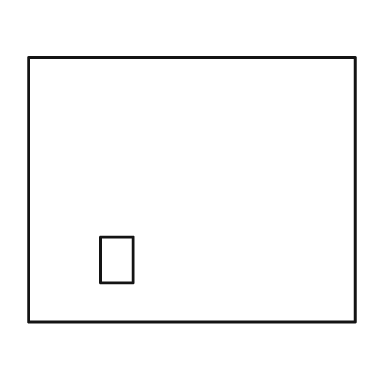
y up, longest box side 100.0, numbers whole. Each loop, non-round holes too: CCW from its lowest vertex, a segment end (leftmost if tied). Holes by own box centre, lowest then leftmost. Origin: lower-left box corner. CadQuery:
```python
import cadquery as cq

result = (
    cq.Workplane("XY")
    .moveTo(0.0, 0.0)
    .lineTo(100.0, 0.0)
    .lineTo(100.0, 81.0)
    .lineTo(0.0, 81.0)
    .close()
    .moveTo(22.0, 12.0)
    .lineTo(32.0, 12.0)
    .lineTo(32.0, 26.0)
    .lineTo(22.0, 26.0)
    .close()
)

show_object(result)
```